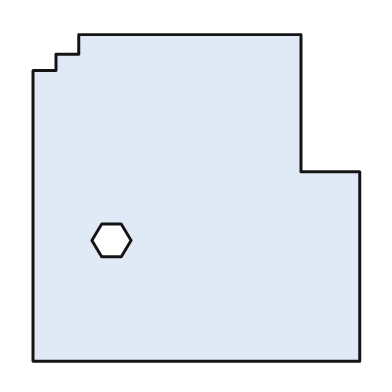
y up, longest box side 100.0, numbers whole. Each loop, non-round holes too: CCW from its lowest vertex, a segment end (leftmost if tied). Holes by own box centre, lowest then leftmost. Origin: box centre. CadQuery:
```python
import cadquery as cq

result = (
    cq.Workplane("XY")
    .moveTo(-50.0, -50.0)
    .lineTo(50.0, -50.0)
    .lineTo(50.0, 8.0)
    .lineTo(32.0, 8.0)
    .lineTo(32.0, 50.0)
    .lineTo(-36.0, 50.0)
    .lineTo(-36.0, 44.0)
    .lineTo(-43.0, 44.0)
    .lineTo(-43.0, 39.0)
    .lineTo(-50.0, 39.0)
    .close()
    .moveTo(-29.0, -18.0)
    .lineTo(-23.0, -18.0)
    .lineTo(-20.0, -13.0)
    .lineTo(-23.0, -8.0)
    .lineTo(-29.0, -8.0)
    .lineTo(-32.0, -13.0)
    .close()
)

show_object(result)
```